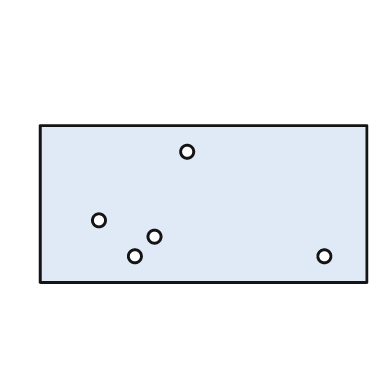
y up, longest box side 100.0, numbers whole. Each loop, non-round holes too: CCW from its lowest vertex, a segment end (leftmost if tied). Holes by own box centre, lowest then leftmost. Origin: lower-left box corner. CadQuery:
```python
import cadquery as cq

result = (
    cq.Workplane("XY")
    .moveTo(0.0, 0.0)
    .lineTo(100.0, 0.0)
    .lineTo(100.0, 48.0)
    .lineTo(0.0, 48.0)
    .close()
    .moveTo(29.0, 8.0)
    .circle(2.0)
    .moveTo(87.0, 8.0)
    .circle(2.0)
    .moveTo(35.0, 14.0)
    .circle(2.0)
    .moveTo(18.0, 19.0)
    .circle(2.0)
    .moveTo(45.0, 40.0)
    .circle(2.0)
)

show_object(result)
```